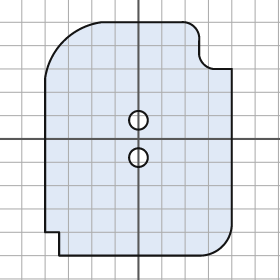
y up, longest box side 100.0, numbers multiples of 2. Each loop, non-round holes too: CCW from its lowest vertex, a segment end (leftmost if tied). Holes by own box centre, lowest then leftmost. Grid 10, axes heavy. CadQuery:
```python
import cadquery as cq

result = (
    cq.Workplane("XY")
    .moveTo(-34.0, -50.0)
    .lineTo(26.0, -50.0)
    .threePointArc((36.0, -46.0), (40.0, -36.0))
    .lineTo(40.0, 30.0)
    .lineTo(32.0, 30.0)
    .threePointArc((28.0, 32.0), (26.0, 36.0))
    .lineTo(26.0, 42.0)
    .threePointArc((24.0, 48.0), (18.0, 50.0))
    .lineTo(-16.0, 50.0)
    .threePointArc((-32.0, 42.0), (-40.0, 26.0))
    .lineTo(-40.0, -40.0)
    .lineTo(-34.0, -40.0)
    .close()
    .moveTo(0.0, -8.0)
    .circle(4.0)
    .moveTo(0.0, 8.0)
    .circle(4.0)
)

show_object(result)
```